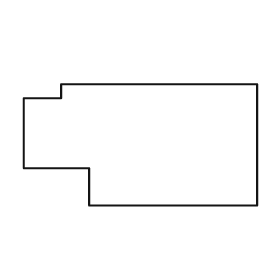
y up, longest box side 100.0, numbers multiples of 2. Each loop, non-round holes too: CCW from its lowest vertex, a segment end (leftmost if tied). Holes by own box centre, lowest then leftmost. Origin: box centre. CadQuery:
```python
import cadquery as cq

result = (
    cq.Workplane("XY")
    .moveTo(-22.0, -26.0)
    .lineTo(50.0, -26.0)
    .lineTo(50.0, 26.0)
    .lineTo(-34.0, 26.0)
    .lineTo(-34.0, 20.0)
    .lineTo(-50.0, 20.0)
    .lineTo(-50.0, -10.0)
    .lineTo(-22.0, -10.0)
    .close()
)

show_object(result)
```